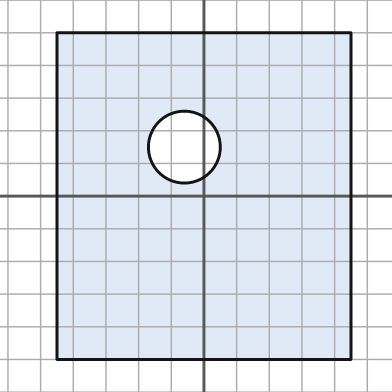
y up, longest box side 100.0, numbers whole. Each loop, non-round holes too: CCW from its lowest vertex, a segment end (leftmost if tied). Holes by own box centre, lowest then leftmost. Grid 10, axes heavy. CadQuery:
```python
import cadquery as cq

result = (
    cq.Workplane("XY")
    .moveTo(-45.0, -50.0)
    .lineTo(45.0, -50.0)
    .lineTo(45.0, 50.0)
    .lineTo(-45.0, 50.0)
    .close()
    .moveTo(-6.0, 15.0)
    .circle(11.0)
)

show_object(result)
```